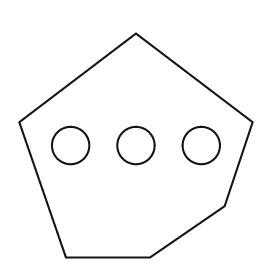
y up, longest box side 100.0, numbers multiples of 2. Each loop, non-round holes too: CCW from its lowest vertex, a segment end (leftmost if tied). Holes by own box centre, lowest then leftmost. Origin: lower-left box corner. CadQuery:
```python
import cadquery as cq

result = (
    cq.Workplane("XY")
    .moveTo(20.0, 0.0)
    .lineTo(56.0, 0.0)
    .lineTo(88.0, 22.0)
    .lineTo(100.0, 58.0)
    .lineTo(50.0, 96.0)
    .lineTo(0.0, 58.0)
    .close()
    .moveTo(22.0, 48.0)
    .circle(8.0)
    .moveTo(50.0, 48.0)
    .circle(8.0)
    .moveTo(78.0, 48.0)
    .circle(8.0)
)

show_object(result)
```